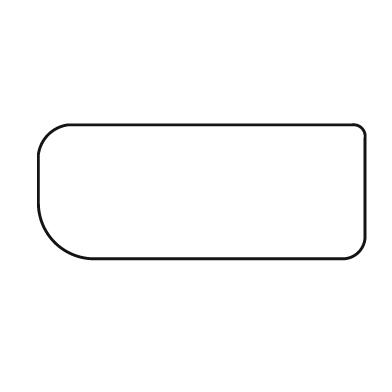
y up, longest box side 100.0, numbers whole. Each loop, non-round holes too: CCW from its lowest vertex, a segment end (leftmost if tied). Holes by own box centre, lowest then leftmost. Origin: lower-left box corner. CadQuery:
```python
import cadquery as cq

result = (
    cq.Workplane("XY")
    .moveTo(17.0, 0.0)
    .lineTo(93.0, 0.0)
    .threePointArc((98.0, 2.0), (100.0, 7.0))
    .lineTo(100.0, 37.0)
    .threePointArc((99.0, 40.0), (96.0, 41.0))
    .lineTo(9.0, 41.0)
    .threePointArc((3.0, 38.0), (0.0, 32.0))
    .lineTo(0.0, 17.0)
    .threePointArc((5.0, 5.0), (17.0, 0.0))
    .close()
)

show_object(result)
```